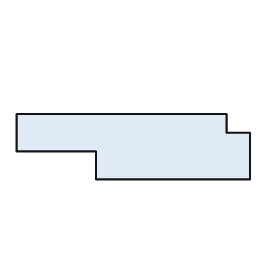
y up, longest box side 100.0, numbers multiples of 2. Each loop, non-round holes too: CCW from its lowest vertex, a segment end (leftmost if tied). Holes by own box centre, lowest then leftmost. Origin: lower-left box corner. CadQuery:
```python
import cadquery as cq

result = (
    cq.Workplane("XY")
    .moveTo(34.0, 0.0)
    .lineTo(100.0, 0.0)
    .lineTo(100.0, 20.0)
    .lineTo(90.0, 20.0)
    .lineTo(90.0, 28.0)
    .lineTo(0.0, 28.0)
    .lineTo(0.0, 12.0)
    .lineTo(34.0, 12.0)
    .close()
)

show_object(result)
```